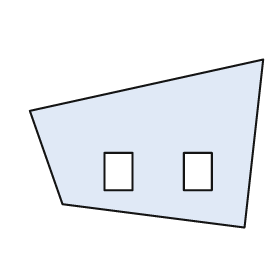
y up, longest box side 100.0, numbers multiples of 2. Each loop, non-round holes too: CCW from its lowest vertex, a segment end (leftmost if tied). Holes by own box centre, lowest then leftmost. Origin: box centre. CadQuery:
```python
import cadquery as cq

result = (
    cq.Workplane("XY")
    .moveTo(42.0, -36.0)
    .lineTo(50.0, 36.0)
    .lineTo(-50.0, 14.0)
    .lineTo(-36.0, -26.0)
    .close()
    .moveTo(-18.0, -20.0)
    .lineTo(-6.0, -20.0)
    .lineTo(-6.0, -4.0)
    .lineTo(-18.0, -4.0)
    .close()
    .moveTo(16.0, -20.0)
    .lineTo(28.0, -20.0)
    .lineTo(28.0, -4.0)
    .lineTo(16.0, -4.0)
    .close()
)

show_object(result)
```